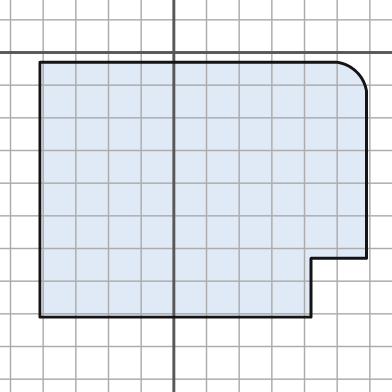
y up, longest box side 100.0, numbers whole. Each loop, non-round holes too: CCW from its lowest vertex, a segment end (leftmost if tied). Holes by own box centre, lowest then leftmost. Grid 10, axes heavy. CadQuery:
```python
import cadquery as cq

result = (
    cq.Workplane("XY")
    .moveTo(-41.0, -81.0)
    .lineTo(42.0, -81.0)
    .lineTo(42.0, -63.0)
    .lineTo(59.0, -63.0)
    .lineTo(59.0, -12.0)
    .threePointArc((56.0, -6.0), (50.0, -3.0))
    .lineTo(-41.0, -3.0)
    .close()
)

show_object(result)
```